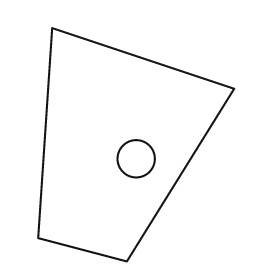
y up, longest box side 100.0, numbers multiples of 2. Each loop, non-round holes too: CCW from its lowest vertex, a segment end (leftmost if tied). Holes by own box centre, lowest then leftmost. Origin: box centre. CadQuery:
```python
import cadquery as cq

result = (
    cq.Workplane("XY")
    .moveTo(-4.0, -50.0)
    .lineTo(42.0, 24.0)
    .lineTo(-36.0, 50.0)
    .lineTo(-42.0, -40.0)
    .close()
    .moveTo(0.0, -6.0)
    .circle(8.0)
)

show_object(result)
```